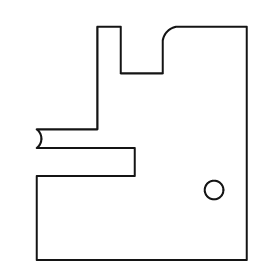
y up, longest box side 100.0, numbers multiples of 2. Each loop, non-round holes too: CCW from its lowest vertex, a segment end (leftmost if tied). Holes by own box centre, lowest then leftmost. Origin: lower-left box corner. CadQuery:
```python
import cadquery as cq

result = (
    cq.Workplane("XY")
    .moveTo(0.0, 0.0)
    .lineTo(90.0, 0.0)
    .lineTo(90.0, 100.0)
    .lineTo(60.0, 100.0)
    .threePointArc((56.0, 98.0), (54.0, 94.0))
    .lineTo(54.0, 80.0)
    .lineTo(36.0, 80.0)
    .lineTo(36.0, 100.0)
    .lineTo(26.0, 100.0)
    .lineTo(26.0, 56.0)
    .lineTo(0.0, 56.0)
    .threePointArc((2.0, 52.0), (0.0, 48.0))
    .lineTo(42.0, 48.0)
    .lineTo(42.0, 36.0)
    .lineTo(0.0, 36.0)
    .close()
    .moveTo(76.0, 30.0)
    .circle(4.0)
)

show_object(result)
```